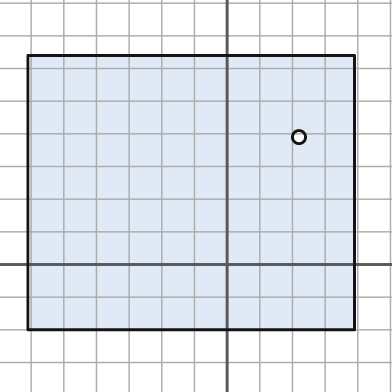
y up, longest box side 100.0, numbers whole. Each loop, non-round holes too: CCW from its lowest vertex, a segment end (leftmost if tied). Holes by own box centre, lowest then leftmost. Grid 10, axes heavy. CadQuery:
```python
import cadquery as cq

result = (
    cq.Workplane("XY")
    .moveTo(-61.0, -20.0)
    .lineTo(39.0, -20.0)
    .lineTo(39.0, 64.0)
    .lineTo(-61.0, 64.0)
    .close()
    .moveTo(22.0, 39.0)
    .circle(2.0)
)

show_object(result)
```